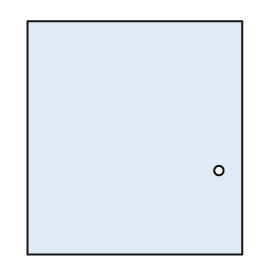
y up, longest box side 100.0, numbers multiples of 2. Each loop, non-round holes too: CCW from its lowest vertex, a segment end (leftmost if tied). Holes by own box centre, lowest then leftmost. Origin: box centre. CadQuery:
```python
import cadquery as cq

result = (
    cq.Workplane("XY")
    .moveTo(-46.0, -50.0)
    .lineTo(46.0, -50.0)
    .lineTo(46.0, 50.0)
    .lineTo(-46.0, 50.0)
    .close()
    .moveTo(36.0, -14.0)
    .circle(2.0)
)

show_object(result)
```